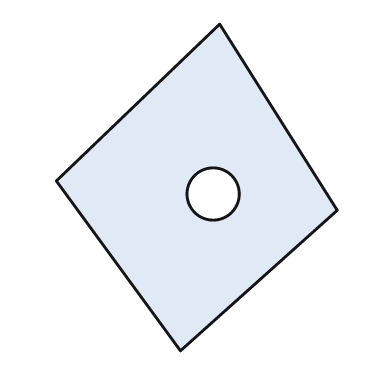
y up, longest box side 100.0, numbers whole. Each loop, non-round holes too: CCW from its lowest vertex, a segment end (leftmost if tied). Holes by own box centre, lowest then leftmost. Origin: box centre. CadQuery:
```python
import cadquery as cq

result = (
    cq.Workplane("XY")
    .moveTo(-5.0, -50.0)
    .lineTo(43.0, -7.0)
    .lineTo(7.0, 50.0)
    .lineTo(-43.0, 2.0)
    .close()
    .moveTo(5.0, -2.0)
    .circle(8.0)
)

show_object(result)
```